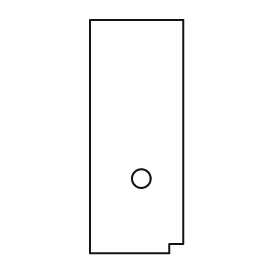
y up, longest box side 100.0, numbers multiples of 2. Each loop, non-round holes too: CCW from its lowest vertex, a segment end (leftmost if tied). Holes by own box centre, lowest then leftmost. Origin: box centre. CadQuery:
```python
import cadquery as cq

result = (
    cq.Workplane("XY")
    .moveTo(-20.0, -50.0)
    .lineTo(14.0, -50.0)
    .lineTo(14.0, -46.0)
    .lineTo(20.0, -46.0)
    .lineTo(20.0, 50.0)
    .lineTo(-20.0, 50.0)
    .close()
    .moveTo(2.0, -18.0)
    .circle(4.0)
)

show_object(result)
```